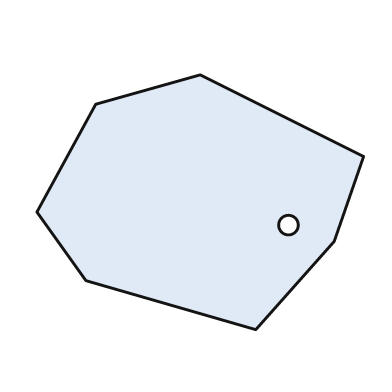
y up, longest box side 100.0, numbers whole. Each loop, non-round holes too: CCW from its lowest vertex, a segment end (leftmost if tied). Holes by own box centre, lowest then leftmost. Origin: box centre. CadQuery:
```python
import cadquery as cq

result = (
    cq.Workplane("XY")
    .moveTo(17.0, -39.0)
    .lineTo(41.0, -12.0)
    .lineTo(50.0, 14.0)
    .lineTo(0.0, 39.0)
    .lineTo(-32.0, 30.0)
    .lineTo(-50.0, -3.0)
    .lineTo(-35.0, -24.0)
    .close()
    .moveTo(27.0, -7.0)
    .circle(3.0)
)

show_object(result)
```